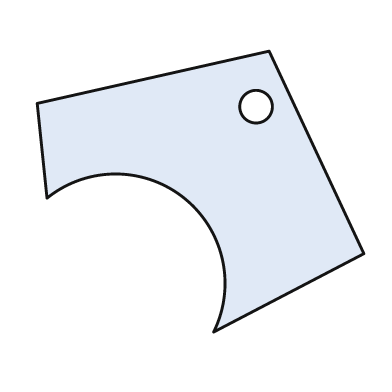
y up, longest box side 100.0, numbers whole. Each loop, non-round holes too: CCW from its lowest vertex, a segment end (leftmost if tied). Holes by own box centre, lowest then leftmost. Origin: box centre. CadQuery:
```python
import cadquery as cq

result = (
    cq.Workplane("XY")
    .moveTo(4.0, -43.0)
    .lineTo(50.0, -19.0)
    .lineTo(21.0, 43.0)
    .lineTo(-50.0, 27.0)
    .lineTo(-47.0, -2.0)
    .threePointArc((-5.0, -2.0), (4.0, -43.0))
    .close()
    .moveTo(17.0, 26.0)
    .circle(5.0)
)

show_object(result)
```